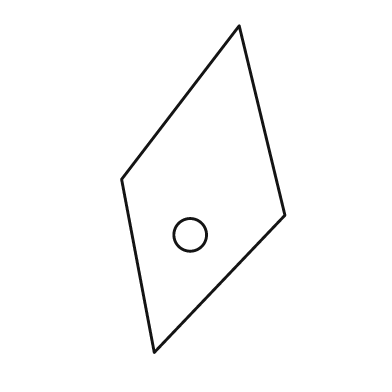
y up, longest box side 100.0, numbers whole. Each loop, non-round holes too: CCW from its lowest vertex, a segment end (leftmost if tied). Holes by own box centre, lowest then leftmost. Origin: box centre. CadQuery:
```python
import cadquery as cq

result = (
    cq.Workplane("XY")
    .moveTo(-15.0, -50.0)
    .lineTo(25.0, -8.0)
    .lineTo(11.0, 50.0)
    .lineTo(-25.0, 3.0)
    .close()
    .moveTo(-4.0, -14.0)
    .circle(5.0)
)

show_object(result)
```